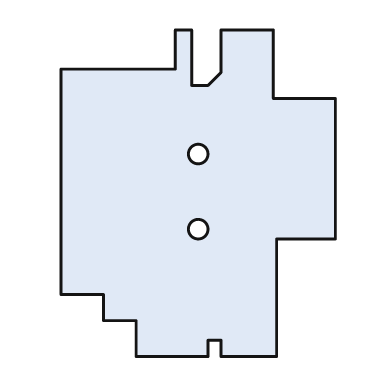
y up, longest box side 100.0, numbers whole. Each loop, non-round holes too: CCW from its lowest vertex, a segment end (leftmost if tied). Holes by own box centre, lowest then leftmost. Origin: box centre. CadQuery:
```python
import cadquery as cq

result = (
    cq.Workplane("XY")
    .moveTo(-19.0, -50.0)
    .lineTo(3.0, -50.0)
    .lineTo(3.0, -45.0)
    .lineTo(7.0, -45.0)
    .lineTo(7.0, -50.0)
    .lineTo(24.0, -50.0)
    .lineTo(24.0, -14.0)
    .lineTo(42.0, -14.0)
    .lineTo(42.0, 29.0)
    .lineTo(23.0, 29.0)
    .lineTo(23.0, 50.0)
    .lineTo(7.0, 50.0)
    .lineTo(7.0, 37.0)
    .lineTo(3.0, 33.0)
    .lineTo(-2.0, 33.0)
    .lineTo(-2.0, 50.0)
    .lineTo(-7.0, 50.0)
    .lineTo(-7.0, 38.0)
    .lineTo(-42.0, 38.0)
    .lineTo(-42.0, -31.0)
    .lineTo(-29.0, -31.0)
    .lineTo(-29.0, -39.0)
    .lineTo(-19.0, -39.0)
    .close()
    .moveTo(0.0, -11.0)
    .circle(3.0)
    .moveTo(0.0, 12.0)
    .circle(3.0)
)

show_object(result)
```